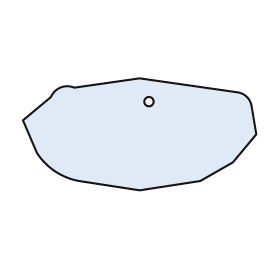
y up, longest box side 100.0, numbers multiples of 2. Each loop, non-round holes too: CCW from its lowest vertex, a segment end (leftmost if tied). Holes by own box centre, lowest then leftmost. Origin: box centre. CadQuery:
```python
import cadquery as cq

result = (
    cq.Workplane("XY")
    .moveTo(0.0, -24.0)
    .lineTo(26.0, -20.0)
    .lineTo(40.0, -12.0)
    .lineTo(50.0, 0.0)
    .lineTo(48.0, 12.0)
    .threePointArc((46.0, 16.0), (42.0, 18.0))
    .lineTo(0.0, 24.0)
    .lineTo(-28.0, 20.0)
    .threePointArc((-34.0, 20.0), (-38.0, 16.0))
    .lineTo(-50.0, 6.0)
    .lineTo(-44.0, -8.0)
    .threePointArc((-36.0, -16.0), (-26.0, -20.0))
    .close()
    .moveTo(4.0, 14.0)
    .circle(2.0)
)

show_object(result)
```